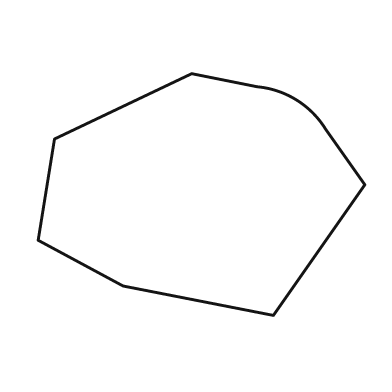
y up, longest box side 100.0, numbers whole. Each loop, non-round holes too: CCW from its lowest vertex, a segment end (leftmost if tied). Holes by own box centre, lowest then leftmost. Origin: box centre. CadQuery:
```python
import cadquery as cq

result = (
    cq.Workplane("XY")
    .moveTo(22.0, -37.0)
    .lineTo(50.0, 3.0)
    .lineTo(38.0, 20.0)
    .threePointArc((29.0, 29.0), (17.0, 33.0))
    .lineTo(-3.0, 37.0)
    .lineTo(-45.0, 17.0)
    .lineTo(-50.0, -14.0)
    .lineTo(-24.0, -28.0)
    .close()
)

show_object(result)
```